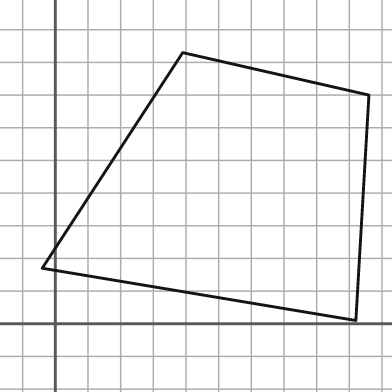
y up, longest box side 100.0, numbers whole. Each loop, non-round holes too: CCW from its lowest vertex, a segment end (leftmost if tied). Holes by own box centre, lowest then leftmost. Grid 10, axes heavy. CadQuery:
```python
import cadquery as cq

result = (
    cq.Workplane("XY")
    .moveTo(92.0, 1.0)
    .lineTo(96.0, 70.0)
    .lineTo(39.0, 83.0)
    .lineTo(-4.0, 17.0)
    .close()
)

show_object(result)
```